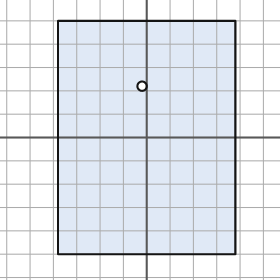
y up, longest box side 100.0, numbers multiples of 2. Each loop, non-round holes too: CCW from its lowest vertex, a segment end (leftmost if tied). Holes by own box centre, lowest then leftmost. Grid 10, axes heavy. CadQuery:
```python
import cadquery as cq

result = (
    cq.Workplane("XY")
    .moveTo(-38.0, -50.0)
    .lineTo(38.0, -50.0)
    .lineTo(38.0, 50.0)
    .lineTo(-38.0, 50.0)
    .close()
    .moveTo(-2.0, 22.0)
    .circle(2.0)
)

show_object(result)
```